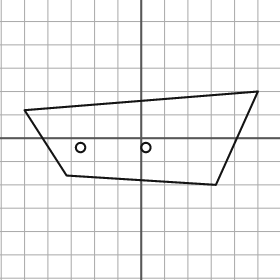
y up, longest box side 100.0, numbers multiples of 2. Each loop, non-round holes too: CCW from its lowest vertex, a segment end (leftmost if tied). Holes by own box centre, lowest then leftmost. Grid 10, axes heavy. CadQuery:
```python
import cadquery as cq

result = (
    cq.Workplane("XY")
    .moveTo(32.0, -20.0)
    .lineTo(50.0, 20.0)
    .lineTo(-50.0, 12.0)
    .lineTo(-32.0, -16.0)
    .close()
    .moveTo(-26.0, -4.0)
    .circle(2.0)
    .moveTo(2.0, -4.0)
    .circle(2.0)
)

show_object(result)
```